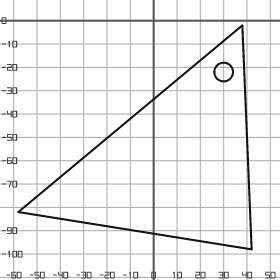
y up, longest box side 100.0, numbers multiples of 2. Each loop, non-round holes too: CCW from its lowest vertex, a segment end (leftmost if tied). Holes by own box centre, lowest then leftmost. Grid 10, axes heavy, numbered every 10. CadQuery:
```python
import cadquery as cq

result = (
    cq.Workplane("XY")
    .moveTo(42.0, -98.0)
    .lineTo(38.0, -2.0)
    .lineTo(-58.0, -82.0)
    .close()
    .moveTo(30.0, -22.0)
    .circle(4.0)
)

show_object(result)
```